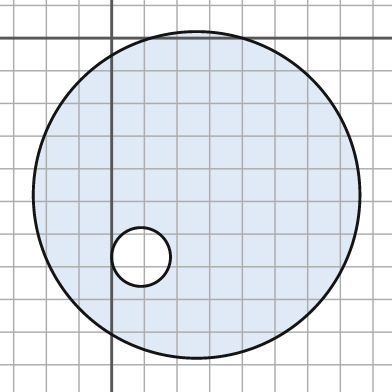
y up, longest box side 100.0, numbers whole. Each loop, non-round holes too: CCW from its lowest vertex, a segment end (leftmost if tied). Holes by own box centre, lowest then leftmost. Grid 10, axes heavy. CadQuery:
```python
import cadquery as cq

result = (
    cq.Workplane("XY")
    .moveTo(26.0, -48.0)
    .circle(50.0)
    .moveTo(9.0, -67.0)
    .circle(9.0)
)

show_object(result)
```